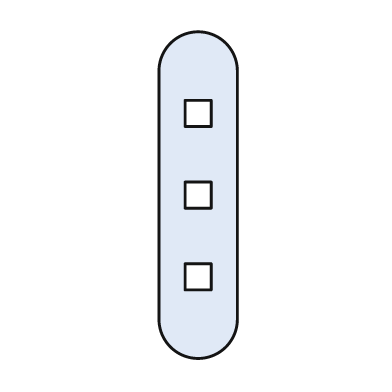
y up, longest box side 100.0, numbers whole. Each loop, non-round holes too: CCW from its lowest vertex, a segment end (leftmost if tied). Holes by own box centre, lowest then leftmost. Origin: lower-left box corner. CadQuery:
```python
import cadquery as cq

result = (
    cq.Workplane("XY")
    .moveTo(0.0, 12.0)
    .threePointArc((12.0, 0.0), (24.0, 12.0))
    .lineTo(24.0, 88.0)
    .threePointArc((12.0, 100.0), (0.0, 88.0))
    .close()
    .moveTo(8.0, 21.0)
    .lineTo(16.0, 21.0)
    .lineTo(16.0, 29.0)
    .lineTo(8.0, 29.0)
    .close()
    .moveTo(8.0, 46.0)
    .lineTo(16.0, 46.0)
    .lineTo(16.0, 54.0)
    .lineTo(8.0, 54.0)
    .close()
    .moveTo(8.0, 71.0)
    .lineTo(16.0, 71.0)
    .lineTo(16.0, 79.0)
    .lineTo(8.0, 79.0)
    .close()
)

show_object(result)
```